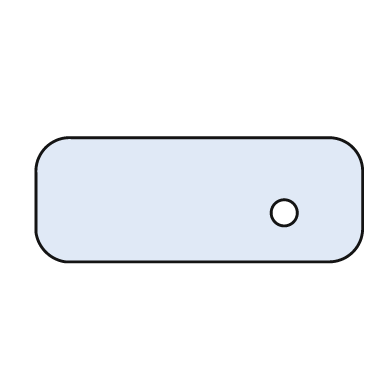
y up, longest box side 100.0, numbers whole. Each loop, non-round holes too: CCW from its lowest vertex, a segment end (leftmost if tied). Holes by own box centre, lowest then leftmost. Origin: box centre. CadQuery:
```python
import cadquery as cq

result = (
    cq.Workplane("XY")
    .moveTo(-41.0, -19.0)
    .lineTo(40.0, -19.0)
    .threePointArc((47.0, -16.0), (50.0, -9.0))
    .lineTo(50.0, 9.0)
    .threePointArc((47.0, 16.0), (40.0, 19.0))
    .lineTo(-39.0, 19.0)
    .threePointArc((-47.0, 16.0), (-50.0, 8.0))
    .lineTo(-50.0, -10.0)
    .threePointArc((-47.0, -16.0), (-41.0, -19.0))
    .close()
    .moveTo(26.0, -4.0)
    .circle(4.0)
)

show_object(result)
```